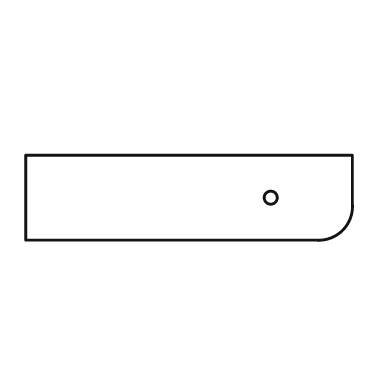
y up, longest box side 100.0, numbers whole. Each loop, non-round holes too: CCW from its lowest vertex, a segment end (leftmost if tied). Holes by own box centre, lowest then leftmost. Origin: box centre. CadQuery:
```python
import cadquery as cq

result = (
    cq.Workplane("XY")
    .moveTo(-50.0, -13.0)
    .lineTo(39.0, -13.0)
    .threePointArc((47.0, -10.0), (50.0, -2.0))
    .lineTo(50.0, 13.0)
    .lineTo(-50.0, 13.0)
    .close()
    .moveTo(25.0, 0.0)
    .circle(2.0)
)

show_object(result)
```